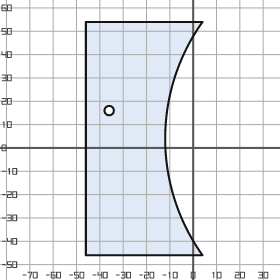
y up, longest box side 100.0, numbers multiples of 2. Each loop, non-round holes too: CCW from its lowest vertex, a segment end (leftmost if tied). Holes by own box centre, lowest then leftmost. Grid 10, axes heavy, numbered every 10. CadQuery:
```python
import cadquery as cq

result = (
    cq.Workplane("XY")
    .moveTo(-46.0, -46.0)
    .lineTo(4.0, -46.0)
    .threePointArc((-12.0, 4.0), (4.0, 54.0))
    .lineTo(-46.0, 54.0)
    .close()
    .moveTo(-36.0, 16.0)
    .circle(2.0)
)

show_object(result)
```